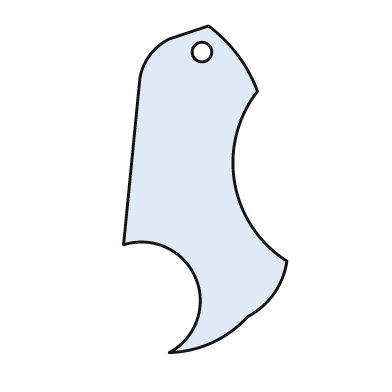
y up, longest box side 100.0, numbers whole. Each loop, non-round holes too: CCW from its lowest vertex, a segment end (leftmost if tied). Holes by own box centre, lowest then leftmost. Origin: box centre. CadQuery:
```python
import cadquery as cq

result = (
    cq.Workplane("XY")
    .moveTo(-11.0, -50.0)
    .threePointArc((2.0, -47.0), (13.0, -39.0))
    .threePointArc((21.0, -32.0), (25.0, -22.0))
    .threePointArc((9.0, 2.0), (16.0, 30.0))
    .threePointArc((10.0, 41.0), (1.0, 50.0))
    .lineTo(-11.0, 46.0)
    .threePointArc((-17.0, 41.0), (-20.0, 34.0))
    .lineTo(-25.0, -17.0)
    .threePointArc((-3.0, -27.0), (-11.0, -50.0))
    .close()
    .moveTo(-1.0, 42.0)
    .circle(3.0)
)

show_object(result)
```